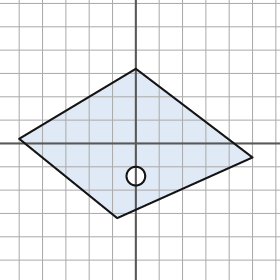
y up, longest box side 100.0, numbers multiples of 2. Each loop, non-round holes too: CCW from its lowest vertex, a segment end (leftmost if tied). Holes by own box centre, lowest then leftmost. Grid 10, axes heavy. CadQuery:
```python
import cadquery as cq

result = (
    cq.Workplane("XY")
    .moveTo(-8.0, -32.0)
    .lineTo(50.0, -6.0)
    .lineTo(0.0, 32.0)
    .lineTo(-50.0, 2.0)
    .close()
    .moveTo(0.0, -14.0)
    .circle(4.0)
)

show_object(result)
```